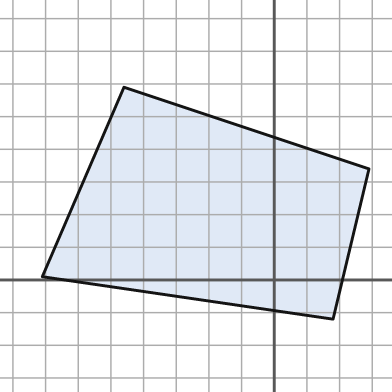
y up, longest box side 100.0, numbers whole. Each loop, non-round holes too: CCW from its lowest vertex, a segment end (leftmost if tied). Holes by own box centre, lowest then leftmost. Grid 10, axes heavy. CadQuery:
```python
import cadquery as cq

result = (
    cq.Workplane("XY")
    .moveTo(18.0, -12.0)
    .lineTo(29.0, 34.0)
    .lineTo(-46.0, 59.0)
    .lineTo(-71.0, 1.0)
    .close()
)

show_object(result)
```